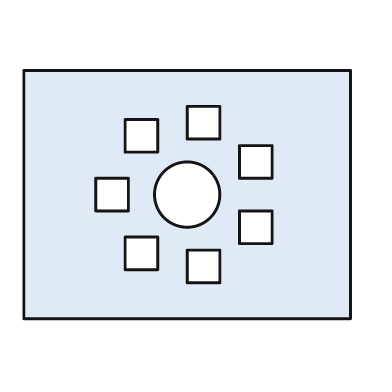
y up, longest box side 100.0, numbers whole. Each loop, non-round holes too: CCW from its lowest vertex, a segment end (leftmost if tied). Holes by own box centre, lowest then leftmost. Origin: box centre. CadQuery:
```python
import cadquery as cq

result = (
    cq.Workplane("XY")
    .moveTo(-50.0, -38.0)
    .lineTo(50.0, -38.0)
    .lineTo(50.0, 38.0)
    .lineTo(-50.0, 38.0)
    .close()
    .moveTo(0.0, -27.0)
    .lineTo(10.0, -27.0)
    .lineTo(10.0, -17.0)
    .lineTo(0.0, -17.0)
    .close()
    .moveTo(-19.0, -23.0)
    .lineTo(-9.0, -23.0)
    .lineTo(-9.0, -13.0)
    .lineTo(-19.0, -13.0)
    .close()
    .moveTo(16.0, -15.0)
    .lineTo(26.0, -15.0)
    .lineTo(26.0, -5.0)
    .lineTo(16.0, -5.0)
    .close()
    .moveTo(-28.0, -5.0)
    .lineTo(-18.0, -5.0)
    .lineTo(-18.0, 5.0)
    .lineTo(-28.0, 5.0)
    .close()
    .moveTo(0.0, 0.0)
    .circle(10.0)
    .moveTo(16.0, 5.0)
    .lineTo(26.0, 5.0)
    .lineTo(26.0, 15.0)
    .lineTo(16.0, 15.0)
    .close()
    .moveTo(-19.0, 13.0)
    .lineTo(-9.0, 13.0)
    .lineTo(-9.0, 23.0)
    .lineTo(-19.0, 23.0)
    .close()
    .moveTo(0.0, 17.0)
    .lineTo(10.0, 17.0)
    .lineTo(10.0, 27.0)
    .lineTo(0.0, 27.0)
    .close()
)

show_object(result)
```